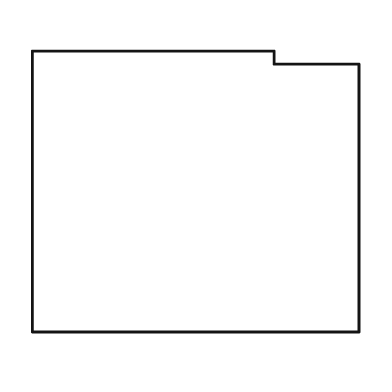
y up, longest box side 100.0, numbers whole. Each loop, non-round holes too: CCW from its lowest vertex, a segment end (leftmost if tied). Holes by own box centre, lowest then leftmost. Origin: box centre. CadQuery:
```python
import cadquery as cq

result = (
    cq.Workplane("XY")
    .moveTo(-50.0, -43.0)
    .lineTo(50.0, -43.0)
    .lineTo(50.0, 39.0)
    .lineTo(24.0, 39.0)
    .lineTo(24.0, 43.0)
    .lineTo(-50.0, 43.0)
    .close()
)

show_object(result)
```